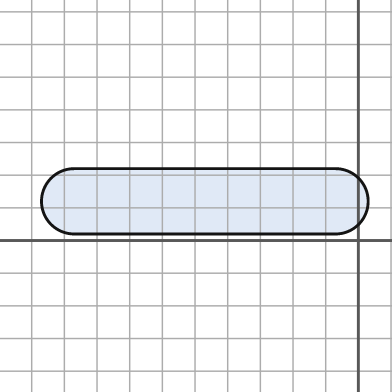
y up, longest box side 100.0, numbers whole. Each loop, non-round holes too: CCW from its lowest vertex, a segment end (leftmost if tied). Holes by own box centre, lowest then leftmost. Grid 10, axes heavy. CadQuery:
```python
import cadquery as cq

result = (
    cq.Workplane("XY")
    .moveTo(-87.0, 2.0)
    .lineTo(-7.0, 2.0)
    .threePointArc((3.0, 12.0), (-7.0, 22.0))
    .lineTo(-87.0, 22.0)
    .threePointArc((-97.0, 12.0), (-87.0, 2.0))
    .close()
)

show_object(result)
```